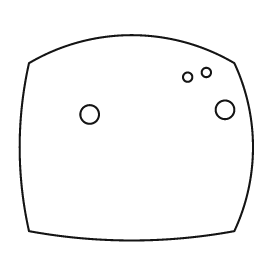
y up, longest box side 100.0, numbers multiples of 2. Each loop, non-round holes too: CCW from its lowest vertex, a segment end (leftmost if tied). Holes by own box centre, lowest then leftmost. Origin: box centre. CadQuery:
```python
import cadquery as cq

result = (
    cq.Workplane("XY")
    .moveTo(-46.0, -40.0)
    .threePointArc((-2.0, -44.0), (42.0, -40.0))
    .threePointArc((50.0, -4.0), (42.0, 32.0))
    .threePointArc((-2.0, 44.0), (-46.0, 32.0))
    .threePointArc((-50.0, -4.0), (-46.0, -40.0))
    .close()
    .moveTo(-20.0, 10.0)
    .circle(4.0)
    .moveTo(38.0, 12.0)
    .circle(4.0)
    .moveTo(22.0, 26.0)
    .circle(2.0)
    .moveTo(30.0, 28.0)
    .circle(2.0)
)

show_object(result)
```